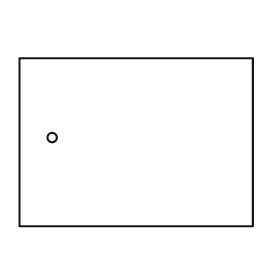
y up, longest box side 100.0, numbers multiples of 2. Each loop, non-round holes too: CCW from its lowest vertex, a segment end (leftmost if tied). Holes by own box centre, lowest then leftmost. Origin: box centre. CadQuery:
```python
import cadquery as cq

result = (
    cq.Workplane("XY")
    .moveTo(-50.0, -36.0)
    .lineTo(50.0, -36.0)
    .lineTo(50.0, 36.0)
    .lineTo(-50.0, 36.0)
    .close()
    .moveTo(-36.0, 2.0)
    .circle(2.0)
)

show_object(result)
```